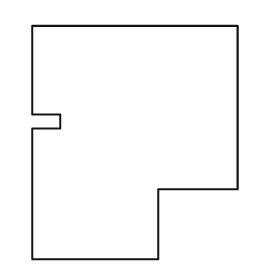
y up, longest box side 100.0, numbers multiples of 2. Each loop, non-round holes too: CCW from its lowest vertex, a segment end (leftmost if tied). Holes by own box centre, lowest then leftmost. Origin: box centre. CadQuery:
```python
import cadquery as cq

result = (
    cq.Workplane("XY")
    .moveTo(-44.0, -50.0)
    .lineTo(10.0, -50.0)
    .lineTo(10.0, -20.0)
    .lineTo(44.0, -20.0)
    .lineTo(44.0, 50.0)
    .lineTo(-44.0, 50.0)
    .lineTo(-44.0, 12.0)
    .lineTo(-32.0, 12.0)
    .lineTo(-32.0, 6.0)
    .lineTo(-44.0, 6.0)
    .close()
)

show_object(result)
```